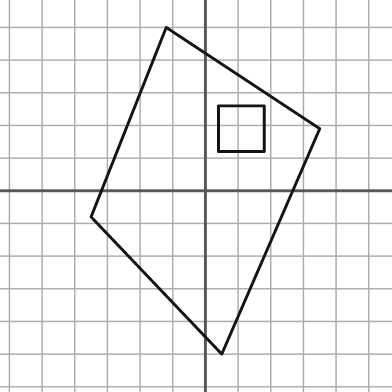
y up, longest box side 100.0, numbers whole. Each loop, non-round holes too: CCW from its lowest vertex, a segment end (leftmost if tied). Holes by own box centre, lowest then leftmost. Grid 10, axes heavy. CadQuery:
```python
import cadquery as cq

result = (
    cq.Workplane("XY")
    .moveTo(5.0, -50.0)
    .lineTo(35.0, 19.0)
    .lineTo(-12.0, 50.0)
    .lineTo(-35.0, -8.0)
    .close()
    .moveTo(4.0, 12.0)
    .lineTo(18.0, 12.0)
    .lineTo(18.0, 26.0)
    .lineTo(4.0, 26.0)
    .close()
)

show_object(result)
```